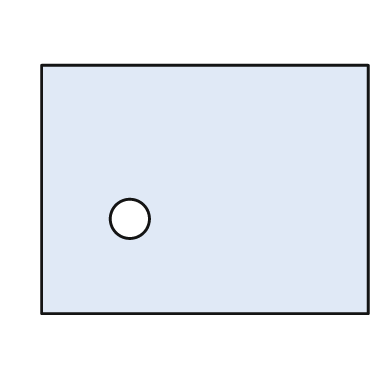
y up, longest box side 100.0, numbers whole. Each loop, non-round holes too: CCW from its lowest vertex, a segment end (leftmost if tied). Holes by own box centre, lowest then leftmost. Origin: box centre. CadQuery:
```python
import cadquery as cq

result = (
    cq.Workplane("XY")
    .moveTo(-50.0, -38.0)
    .lineTo(50.0, -38.0)
    .lineTo(50.0, 38.0)
    .lineTo(-50.0, 38.0)
    .close()
    .moveTo(-23.0, -9.0)
    .circle(6.0)
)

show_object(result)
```